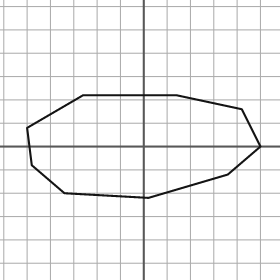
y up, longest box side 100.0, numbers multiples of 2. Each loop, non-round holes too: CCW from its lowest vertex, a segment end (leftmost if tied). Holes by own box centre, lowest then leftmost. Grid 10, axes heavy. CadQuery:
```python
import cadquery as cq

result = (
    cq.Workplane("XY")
    .moveTo(2.0, -22.0)
    .lineTo(36.0, -12.0)
    .lineTo(50.0, 0.0)
    .lineTo(42.0, 16.0)
    .lineTo(14.0, 22.0)
    .lineTo(-26.0, 22.0)
    .lineTo(-50.0, 8.0)
    .lineTo(-48.0, -8.0)
    .lineTo(-34.0, -20.0)
    .close()
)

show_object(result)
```